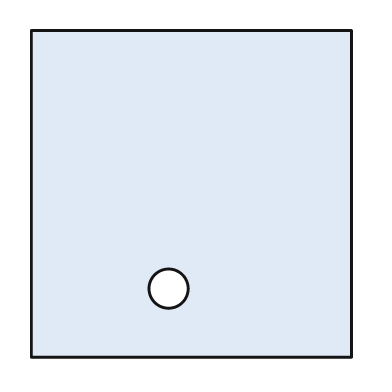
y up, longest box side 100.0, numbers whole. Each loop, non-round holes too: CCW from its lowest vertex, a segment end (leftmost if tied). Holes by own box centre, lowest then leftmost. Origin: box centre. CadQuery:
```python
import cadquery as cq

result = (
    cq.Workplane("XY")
    .moveTo(-49.0, -50.0)
    .lineTo(49.0, -50.0)
    .lineTo(49.0, 50.0)
    .lineTo(-49.0, 50.0)
    .close()
    .moveTo(-7.0, -29.0)
    .circle(6.0)
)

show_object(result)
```